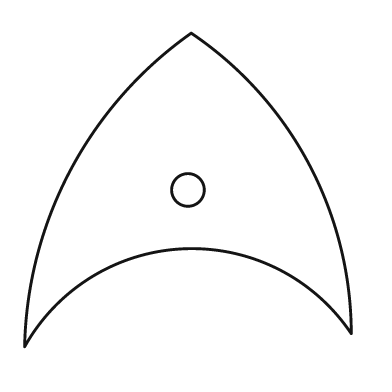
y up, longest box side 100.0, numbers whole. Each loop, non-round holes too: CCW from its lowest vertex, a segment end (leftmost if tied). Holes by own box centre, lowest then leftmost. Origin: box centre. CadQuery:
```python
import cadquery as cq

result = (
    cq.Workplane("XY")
    .moveTo(-50.0, -48.0)
    .threePointArc((-1.0, -18.0), (50.0, -44.0))
    .threePointArc((37.0, 8.0), (1.0, 48.0))
    .threePointArc((-36.0, 6.0), (-50.0, -48.0))
    .close()
    .moveTo(0.0, 0.0)
    .circle(5.0)
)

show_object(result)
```